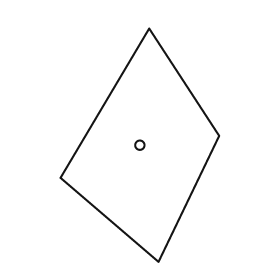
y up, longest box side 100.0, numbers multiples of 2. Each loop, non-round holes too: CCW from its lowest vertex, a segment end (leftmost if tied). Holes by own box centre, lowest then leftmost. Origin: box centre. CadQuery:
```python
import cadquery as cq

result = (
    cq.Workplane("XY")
    .moveTo(8.0, -50.0)
    .lineTo(34.0, 4.0)
    .lineTo(4.0, 50.0)
    .lineTo(-34.0, -14.0)
    .close()
    .moveTo(0.0, 0.0)
    .circle(2.0)
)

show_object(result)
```